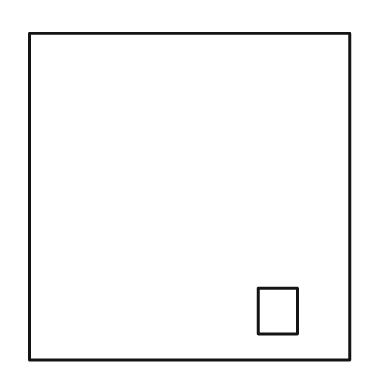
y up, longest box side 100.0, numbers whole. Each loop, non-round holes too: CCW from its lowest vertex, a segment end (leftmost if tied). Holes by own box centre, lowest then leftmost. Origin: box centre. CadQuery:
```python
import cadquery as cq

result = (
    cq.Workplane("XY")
    .moveTo(-49.0, -50.0)
    .lineTo(49.0, -50.0)
    .lineTo(49.0, 50.0)
    .lineTo(-49.0, 50.0)
    .close()
    .moveTo(21.0, -42.0)
    .lineTo(33.0, -42.0)
    .lineTo(33.0, -28.0)
    .lineTo(21.0, -28.0)
    .close()
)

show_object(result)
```